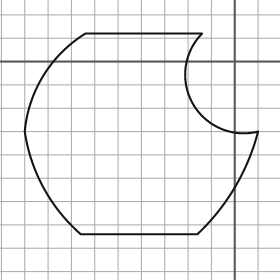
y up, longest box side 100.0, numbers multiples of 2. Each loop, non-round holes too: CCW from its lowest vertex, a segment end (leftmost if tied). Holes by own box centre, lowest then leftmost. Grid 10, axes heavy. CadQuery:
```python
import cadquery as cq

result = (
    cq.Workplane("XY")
    .moveTo(-66.0, -74.0)
    .lineTo(-16.0, -74.0)
    .threePointArc((0.0, -54.0), (10.0, -30.0))
    .threePointArc((-18.0, -18.0), (-14.0, 12.0))
    .lineTo(-64.0, 12.0)
    .threePointArc((-82.0, -6.0), (-90.0, -30.0))
    .threePointArc((-82.0, -54.0), (-66.0, -74.0))
    .close()
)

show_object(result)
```